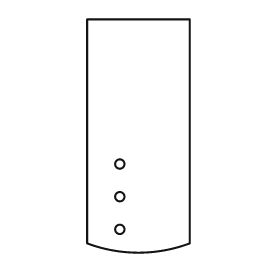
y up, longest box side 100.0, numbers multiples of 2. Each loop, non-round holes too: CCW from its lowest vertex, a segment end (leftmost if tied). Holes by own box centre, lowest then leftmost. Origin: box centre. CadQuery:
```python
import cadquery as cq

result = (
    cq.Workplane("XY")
    .moveTo(-22.0, -46.0)
    .threePointArc((0.0, -50.0), (22.0, -46.0))
    .lineTo(22.0, 50.0)
    .lineTo(-22.0, 50.0)
    .close()
    .moveTo(-8.0, -40.0)
    .circle(2.0)
    .moveTo(-8.0, -26.0)
    .circle(2.0)
    .moveTo(-8.0, -12.0)
    .circle(2.0)
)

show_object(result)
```